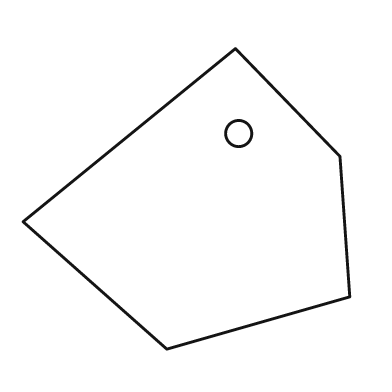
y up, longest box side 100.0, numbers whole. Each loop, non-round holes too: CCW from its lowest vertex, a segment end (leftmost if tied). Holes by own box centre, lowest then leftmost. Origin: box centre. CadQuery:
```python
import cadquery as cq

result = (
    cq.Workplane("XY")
    .moveTo(-6.0, -46.0)
    .lineTo(50.0, -30.0)
    .lineTo(47.0, 13.0)
    .lineTo(15.0, 46.0)
    .lineTo(-50.0, -7.0)
    .close()
    .moveTo(16.0, 20.0)
    .circle(4.0)
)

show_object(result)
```